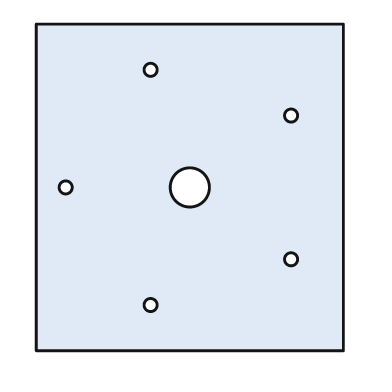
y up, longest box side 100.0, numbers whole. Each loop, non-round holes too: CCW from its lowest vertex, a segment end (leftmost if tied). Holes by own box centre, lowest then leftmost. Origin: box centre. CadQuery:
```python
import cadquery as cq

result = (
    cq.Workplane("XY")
    .moveTo(-47.0, -50.0)
    .lineTo(47.0, -50.0)
    .lineTo(47.0, 50.0)
    .lineTo(-47.0, 50.0)
    .close()
    .moveTo(-12.0, -36.0)
    .circle(2.0)
    .moveTo(31.0, -22.0)
    .circle(2.0)
    .moveTo(-38.0, 0.0)
    .circle(2.0)
    .moveTo(0.0, 0.0)
    .circle(6.0)
    .moveTo(31.0, 22.0)
    .circle(2.0)
    .moveTo(-12.0, 36.0)
    .circle(2.0)
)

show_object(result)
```